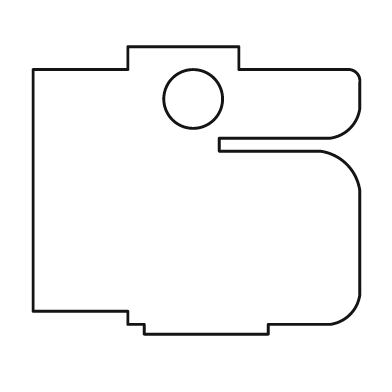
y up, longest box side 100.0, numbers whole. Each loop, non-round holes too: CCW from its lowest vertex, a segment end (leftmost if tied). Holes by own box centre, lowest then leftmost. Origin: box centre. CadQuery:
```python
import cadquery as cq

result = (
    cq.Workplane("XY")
    .moveTo(-16.0, -44.0)
    .lineTo(22.0, -44.0)
    .lineTo(22.0, -41.0)
    .lineTo(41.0, -41.0)
    .threePointArc((47.0, -38.0), (50.0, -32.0))
    .lineTo(50.0, 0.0)
    .threePointArc((46.0, 8.0), (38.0, 12.0))
    .lineTo(7.0, 12.0)
    .lineTo(7.0, 16.0)
    .lineTo(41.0, 16.0)
    .threePointArc((47.0, 19.0), (50.0, 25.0))
    .lineTo(50.0, 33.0)
    .threePointArc((49.0, 36.0), (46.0, 37.0))
    .lineTo(13.0, 37.0)
    .lineTo(13.0, 44.0)
    .lineTo(-21.0, 44.0)
    .lineTo(-21.0, 37.0)
    .lineTo(-50.0, 37.0)
    .lineTo(-50.0, -37.0)
    .lineTo(-21.0, -37.0)
    .lineTo(-21.0, -41.0)
    .lineTo(-16.0, -41.0)
    .close()
    .moveTo(-1.0, 28.0)
    .circle(9.0)
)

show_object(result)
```